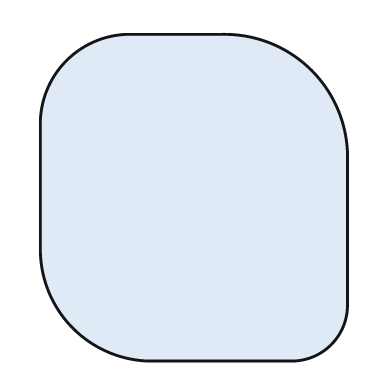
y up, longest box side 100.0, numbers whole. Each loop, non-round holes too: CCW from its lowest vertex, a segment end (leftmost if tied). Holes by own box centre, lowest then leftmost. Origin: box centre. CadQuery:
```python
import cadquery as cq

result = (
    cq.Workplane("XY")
    .moveTo(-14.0, -50.0)
    .lineTo(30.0, -50.0)
    .threePointArc((42.0, -45.0), (47.0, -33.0))
    .lineTo(47.0, 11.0)
    .threePointArc((36.0, 39.0), (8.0, 50.0))
    .lineTo(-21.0, 50.0)
    .threePointArc((-39.0, 42.0), (-47.0, 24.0))
    .lineTo(-47.0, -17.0)
    .threePointArc((-37.0, -40.0), (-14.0, -50.0))
    .close()
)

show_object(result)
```